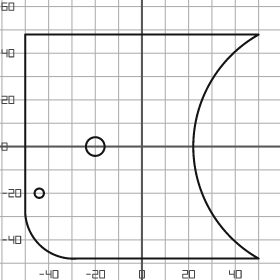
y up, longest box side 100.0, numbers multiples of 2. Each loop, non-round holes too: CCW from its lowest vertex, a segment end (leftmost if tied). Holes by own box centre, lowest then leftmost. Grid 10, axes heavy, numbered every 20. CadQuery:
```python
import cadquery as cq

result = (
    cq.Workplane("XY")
    .moveTo(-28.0, -48.0)
    .lineTo(50.0, -48.0)
    .threePointArc((22.0, 0.0), (50.0, 48.0))
    .lineTo(-50.0, 48.0)
    .lineTo(-50.0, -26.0)
    .threePointArc((-44.0, -42.0), (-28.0, -48.0))
    .close()
    .moveTo(-44.0, -20.0)
    .circle(2.0)
    .moveTo(-20.0, 0.0)
    .circle(4.0)
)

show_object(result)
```